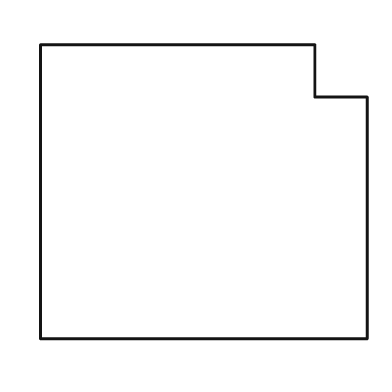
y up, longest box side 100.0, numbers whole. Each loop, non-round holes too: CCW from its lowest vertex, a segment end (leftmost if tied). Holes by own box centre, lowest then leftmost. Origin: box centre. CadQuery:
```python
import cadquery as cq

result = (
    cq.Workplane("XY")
    .moveTo(-50.0, -45.0)
    .lineTo(50.0, -45.0)
    .lineTo(50.0, 29.0)
    .lineTo(34.0, 29.0)
    .lineTo(34.0, 45.0)
    .lineTo(-50.0, 45.0)
    .close()
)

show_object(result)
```